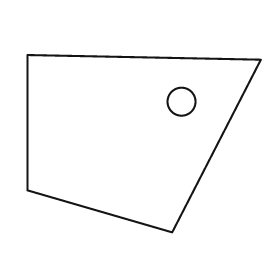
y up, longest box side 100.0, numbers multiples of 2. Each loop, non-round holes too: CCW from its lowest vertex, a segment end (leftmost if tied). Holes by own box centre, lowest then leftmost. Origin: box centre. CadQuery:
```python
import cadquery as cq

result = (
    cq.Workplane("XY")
    .moveTo(12.0, -38.0)
    .lineTo(50.0, 36.0)
    .lineTo(-50.0, 38.0)
    .lineTo(-50.0, -20.0)
    .close()
    .moveTo(16.0, 18.0)
    .circle(6.0)
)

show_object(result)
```